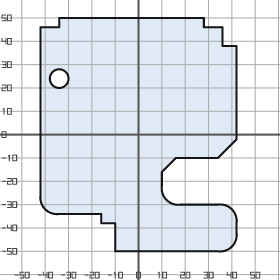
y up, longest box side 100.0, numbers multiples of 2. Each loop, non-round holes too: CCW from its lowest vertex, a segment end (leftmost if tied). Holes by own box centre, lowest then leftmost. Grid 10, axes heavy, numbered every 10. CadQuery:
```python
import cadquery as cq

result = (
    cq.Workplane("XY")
    .moveTo(-10.0, -50.0)
    .lineTo(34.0, -50.0)
    .threePointArc((40.0, -48.0), (42.0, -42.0))
    .lineTo(42.0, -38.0)
    .threePointArc((40.0, -32.0), (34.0, -30.0))
    .lineTo(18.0, -30.0)
    .threePointArc((12.0, -28.0), (10.0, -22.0))
    .lineTo(10.0, -16.0)
    .lineTo(16.0, -10.0)
    .lineTo(34.0, -10.0)
    .lineTo(42.0, -2.0)
    .lineTo(42.0, 38.0)
    .lineTo(36.0, 38.0)
    .lineTo(36.0, 46.0)
    .lineTo(28.0, 46.0)
    .lineTo(28.0, 50.0)
    .lineTo(-34.0, 50.0)
    .lineTo(-34.0, 46.0)
    .lineTo(-42.0, 46.0)
    .lineTo(-42.0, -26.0)
    .threePointArc((-40.0, -32.0), (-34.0, -34.0))
    .lineTo(-16.0, -34.0)
    .lineTo(-16.0, -38.0)
    .lineTo(-10.0, -38.0)
    .close()
    .moveTo(-34.0, 24.0)
    .circle(4.0)
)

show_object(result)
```